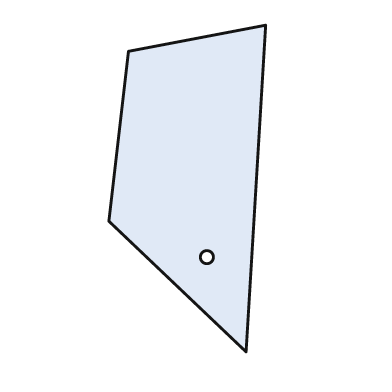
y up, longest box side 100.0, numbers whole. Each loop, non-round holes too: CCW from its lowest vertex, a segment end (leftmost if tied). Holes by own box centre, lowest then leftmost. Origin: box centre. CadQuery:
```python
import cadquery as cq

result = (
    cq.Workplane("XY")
    .moveTo(18.0, -50.0)
    .lineTo(24.0, 50.0)
    .lineTo(-18.0, 42.0)
    .lineTo(-24.0, -10.0)
    .close()
    .moveTo(6.0, -21.0)
    .circle(2.0)
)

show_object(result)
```